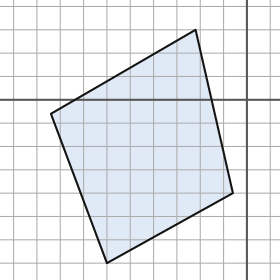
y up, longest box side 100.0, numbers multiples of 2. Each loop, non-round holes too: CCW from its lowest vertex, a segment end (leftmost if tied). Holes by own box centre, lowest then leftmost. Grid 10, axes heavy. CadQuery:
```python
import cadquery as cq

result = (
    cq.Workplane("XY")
    .moveTo(-60.0, -70.0)
    .lineTo(-6.0, -40.0)
    .lineTo(-22.0, 30.0)
    .lineTo(-84.0, -6.0)
    .close()
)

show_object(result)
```